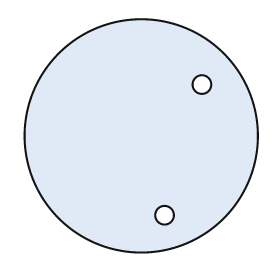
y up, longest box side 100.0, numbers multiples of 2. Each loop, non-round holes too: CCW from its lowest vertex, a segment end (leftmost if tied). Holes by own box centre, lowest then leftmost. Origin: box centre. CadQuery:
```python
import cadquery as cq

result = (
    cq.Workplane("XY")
    .moveTo(0.0, 0.0)
    .circle(50.0)
    .moveTo(10.0, -34.0)
    .circle(4.0)
    .moveTo(26.0, 22.0)
    .circle(4.0)
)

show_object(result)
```